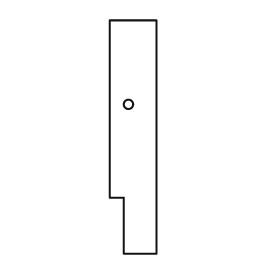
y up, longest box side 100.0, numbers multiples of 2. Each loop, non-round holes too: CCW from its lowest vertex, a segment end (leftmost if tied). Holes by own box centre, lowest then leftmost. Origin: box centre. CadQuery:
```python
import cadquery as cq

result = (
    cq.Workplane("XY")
    .moveTo(-4.0, -50.0)
    .lineTo(10.0, -50.0)
    .lineTo(10.0, 50.0)
    .lineTo(-10.0, 50.0)
    .lineTo(-10.0, -26.0)
    .lineTo(-4.0, -26.0)
    .close()
    .moveTo(-2.0, 14.0)
    .circle(2.0)
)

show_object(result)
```